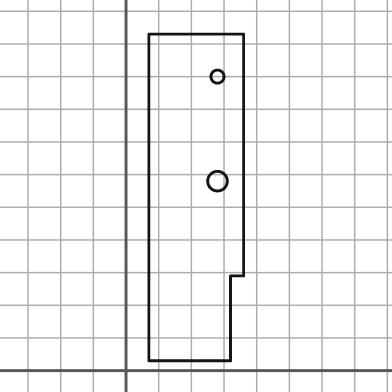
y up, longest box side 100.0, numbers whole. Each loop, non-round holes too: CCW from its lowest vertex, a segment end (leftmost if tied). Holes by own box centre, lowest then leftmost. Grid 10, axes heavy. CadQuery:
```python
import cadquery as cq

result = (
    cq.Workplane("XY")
    .moveTo(7.0, 3.0)
    .lineTo(32.0, 3.0)
    .lineTo(32.0, 29.0)
    .lineTo(36.0, 29.0)
    .lineTo(36.0, 103.0)
    .lineTo(7.0, 103.0)
    .close()
    .moveTo(28.0, 58.0)
    .circle(3.0)
    .moveTo(28.0, 90.0)
    .circle(2.0)
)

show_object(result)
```